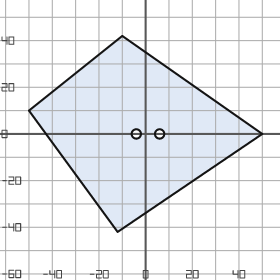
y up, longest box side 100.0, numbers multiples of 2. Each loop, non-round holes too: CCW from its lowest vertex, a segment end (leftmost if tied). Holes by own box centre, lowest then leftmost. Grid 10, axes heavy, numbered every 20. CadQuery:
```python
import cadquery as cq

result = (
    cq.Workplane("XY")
    .moveTo(-12.0, -42.0)
    .lineTo(50.0, 0.0)
    .lineTo(-10.0, 42.0)
    .lineTo(-50.0, 10.0)
    .close()
    .moveTo(-4.0, 0.0)
    .circle(2.0)
    .moveTo(6.0, 0.0)
    .circle(2.0)
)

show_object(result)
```